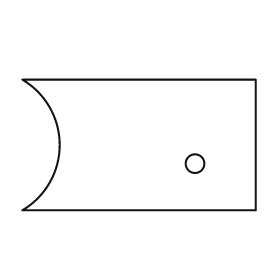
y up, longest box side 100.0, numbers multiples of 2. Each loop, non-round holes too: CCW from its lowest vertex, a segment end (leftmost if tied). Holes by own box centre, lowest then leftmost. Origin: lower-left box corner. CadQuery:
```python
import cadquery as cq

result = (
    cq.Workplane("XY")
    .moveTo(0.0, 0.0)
    .lineTo(100.0, 0.0)
    .lineTo(100.0, 56.0)
    .lineTo(0.0, 56.0)
    .threePointArc((16.0, 28.0), (0.0, 0.0))
    .close()
    .moveTo(74.0, 20.0)
    .circle(4.0)
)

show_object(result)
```